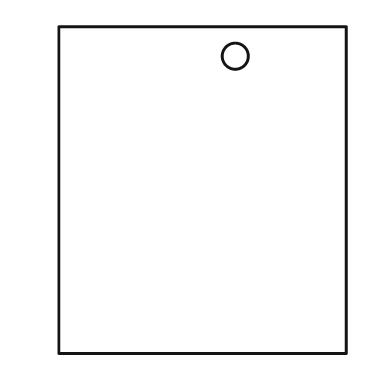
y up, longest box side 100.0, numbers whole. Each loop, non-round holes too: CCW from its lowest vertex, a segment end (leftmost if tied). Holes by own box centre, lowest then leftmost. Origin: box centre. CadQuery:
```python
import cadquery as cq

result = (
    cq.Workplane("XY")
    .moveTo(-44.0, -50.0)
    .lineTo(44.0, -50.0)
    .lineTo(44.0, 50.0)
    .lineTo(-44.0, 50.0)
    .close()
    .moveTo(10.0, 41.0)
    .circle(4.0)
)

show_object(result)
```